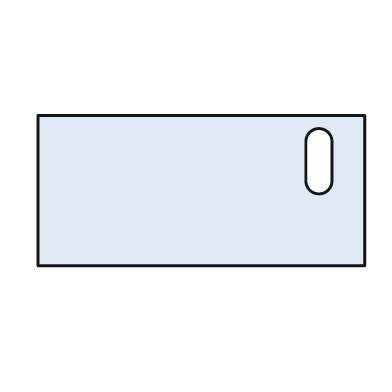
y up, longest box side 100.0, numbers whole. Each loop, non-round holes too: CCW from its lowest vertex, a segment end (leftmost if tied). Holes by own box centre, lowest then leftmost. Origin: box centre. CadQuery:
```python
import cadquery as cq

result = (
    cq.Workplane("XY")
    .moveTo(-50.0, -23.0)
    .lineTo(50.0, -23.0)
    .lineTo(50.0, 23.0)
    .lineTo(-50.0, 23.0)
    .close()
    .moveTo(32.0, 3.0)
    .threePointArc((36.0, -1.0), (40.0, 3.0))
    .lineTo(40.0, 15.0)
    .threePointArc((36.0, 19.0), (32.0, 15.0))
    .close()
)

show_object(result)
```